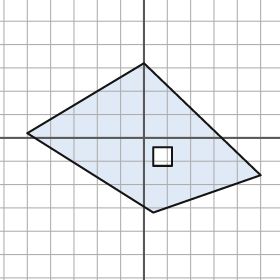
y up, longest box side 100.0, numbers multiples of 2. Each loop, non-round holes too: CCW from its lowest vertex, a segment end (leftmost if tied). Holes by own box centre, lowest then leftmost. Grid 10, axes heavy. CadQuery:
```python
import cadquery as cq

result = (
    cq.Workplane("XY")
    .moveTo(4.0, -32.0)
    .lineTo(50.0, -16.0)
    .lineTo(0.0, 32.0)
    .lineTo(-50.0, 2.0)
    .close()
    .moveTo(4.0, -12.0)
    .lineTo(12.0, -12.0)
    .lineTo(12.0, -4.0)
    .lineTo(4.0, -4.0)
    .close()
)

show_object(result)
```